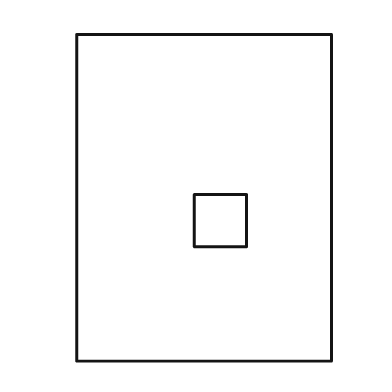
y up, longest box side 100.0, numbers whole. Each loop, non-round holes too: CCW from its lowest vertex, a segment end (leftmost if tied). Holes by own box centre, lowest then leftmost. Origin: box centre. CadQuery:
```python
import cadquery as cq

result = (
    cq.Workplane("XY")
    .moveTo(-39.0, -50.0)
    .lineTo(39.0, -50.0)
    .lineTo(39.0, 50.0)
    .lineTo(-39.0, 50.0)
    .close()
    .moveTo(-3.0, -15.0)
    .lineTo(13.0, -15.0)
    .lineTo(13.0, 1.0)
    .lineTo(-3.0, 1.0)
    .close()
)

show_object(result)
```